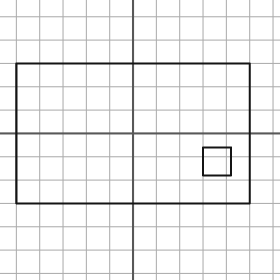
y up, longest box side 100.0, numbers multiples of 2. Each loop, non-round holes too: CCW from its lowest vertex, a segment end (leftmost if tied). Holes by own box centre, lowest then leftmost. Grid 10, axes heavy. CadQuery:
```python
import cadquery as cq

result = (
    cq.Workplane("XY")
    .moveTo(-50.0, -30.0)
    .lineTo(50.0, -30.0)
    .lineTo(50.0, 30.0)
    .lineTo(-50.0, 30.0)
    .close()
    .moveTo(30.0, -18.0)
    .lineTo(42.0, -18.0)
    .lineTo(42.0, -6.0)
    .lineTo(30.0, -6.0)
    .close()
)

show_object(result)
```